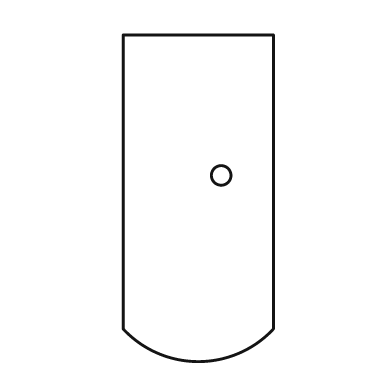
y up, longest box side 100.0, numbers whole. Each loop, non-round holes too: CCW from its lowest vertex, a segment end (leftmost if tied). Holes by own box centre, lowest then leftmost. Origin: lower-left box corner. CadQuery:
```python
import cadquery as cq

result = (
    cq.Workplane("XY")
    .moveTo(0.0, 10.0)
    .threePointArc((23.0, 0.0), (46.0, 10.0))
    .lineTo(46.0, 100.0)
    .lineTo(0.0, 100.0)
    .close()
    .moveTo(30.0, 57.0)
    .circle(3.0)
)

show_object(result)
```